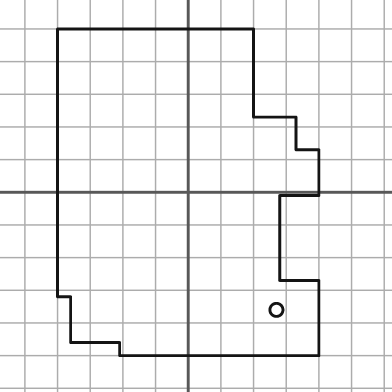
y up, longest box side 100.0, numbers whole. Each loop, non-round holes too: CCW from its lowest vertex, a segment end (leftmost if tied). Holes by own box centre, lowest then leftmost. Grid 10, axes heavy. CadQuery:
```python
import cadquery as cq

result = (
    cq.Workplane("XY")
    .moveTo(-21.0, -50.0)
    .lineTo(40.0, -50.0)
    .lineTo(40.0, -27.0)
    .lineTo(28.0, -27.0)
    .lineTo(28.0, -1.0)
    .lineTo(40.0, -1.0)
    .lineTo(40.0, 13.0)
    .lineTo(33.0, 13.0)
    .lineTo(33.0, 23.0)
    .lineTo(20.0, 23.0)
    .lineTo(20.0, 50.0)
    .lineTo(-40.0, 50.0)
    .lineTo(-40.0, -32.0)
    .lineTo(-36.0, -32.0)
    .lineTo(-36.0, -46.0)
    .lineTo(-21.0, -46.0)
    .close()
    .moveTo(27.0, -36.0)
    .circle(2.0)
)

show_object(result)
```